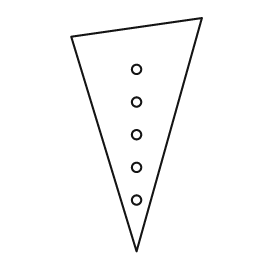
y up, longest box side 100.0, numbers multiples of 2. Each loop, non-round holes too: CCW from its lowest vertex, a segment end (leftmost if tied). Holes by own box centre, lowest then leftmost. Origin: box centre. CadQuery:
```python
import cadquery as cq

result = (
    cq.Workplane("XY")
    .moveTo(0.0, -50.0)
    .lineTo(28.0, 50.0)
    .lineTo(-28.0, 42.0)
    .close()
    .moveTo(0.0, -28.0)
    .circle(2.0)
    .moveTo(0.0, -14.0)
    .circle(2.0)
    .moveTo(0.0, 0.0)
    .circle(2.0)
    .moveTo(0.0, 14.0)
    .circle(2.0)
    .moveTo(0.0, 28.0)
    .circle(2.0)
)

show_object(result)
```